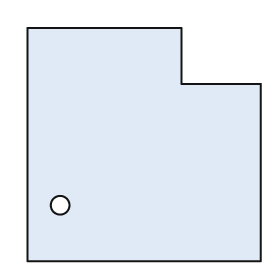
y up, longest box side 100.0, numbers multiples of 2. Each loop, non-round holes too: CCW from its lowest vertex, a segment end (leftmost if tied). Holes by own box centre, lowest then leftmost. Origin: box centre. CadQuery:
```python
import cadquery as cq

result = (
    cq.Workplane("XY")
    .moveTo(-50.0, -50.0)
    .lineTo(50.0, -50.0)
    .lineTo(50.0, 26.0)
    .lineTo(16.0, 26.0)
    .lineTo(16.0, 50.0)
    .lineTo(-50.0, 50.0)
    .close()
    .moveTo(-36.0, -26.0)
    .circle(4.0)
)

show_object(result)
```